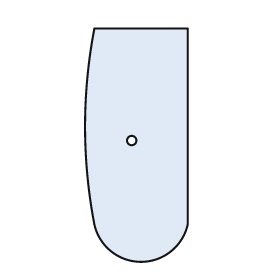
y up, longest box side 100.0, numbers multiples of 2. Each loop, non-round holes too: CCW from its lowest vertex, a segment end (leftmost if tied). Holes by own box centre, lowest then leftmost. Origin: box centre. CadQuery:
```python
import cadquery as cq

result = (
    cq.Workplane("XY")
    .moveTo(-18.0, -34.0)
    .threePointArc((2.0, -50.0), (22.0, -34.0))
    .lineTo(22.0, 50.0)
    .lineTo(-18.0, 50.0)
    .threePointArc((-22.0, 8.0), (-18.0, -34.0))
    .close()
    .moveTo(-2.0, 2.0)
    .circle(2.0)
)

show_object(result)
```